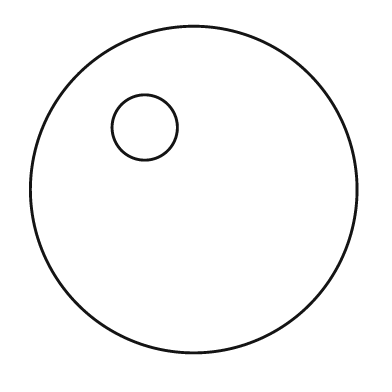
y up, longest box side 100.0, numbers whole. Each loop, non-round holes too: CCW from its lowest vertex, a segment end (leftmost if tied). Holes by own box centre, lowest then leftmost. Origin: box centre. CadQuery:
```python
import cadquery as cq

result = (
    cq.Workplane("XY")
    .moveTo(0.0, 0.0)
    .circle(50.0)
    .moveTo(-15.0, 19.0)
    .circle(10.0)
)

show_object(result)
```